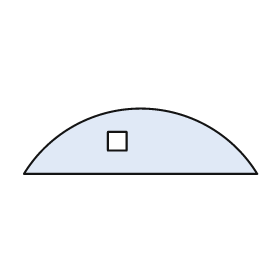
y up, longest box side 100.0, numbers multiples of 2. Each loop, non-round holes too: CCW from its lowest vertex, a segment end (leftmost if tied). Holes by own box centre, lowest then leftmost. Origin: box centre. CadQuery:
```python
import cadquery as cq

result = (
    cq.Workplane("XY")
    .moveTo(-50.0, -14.0)
    .lineTo(50.0, -14.0)
    .threePointArc((0.0, 14.0), (-50.0, -14.0))
    .close()
    .moveTo(-14.0, -4.0)
    .lineTo(-6.0, -4.0)
    .lineTo(-6.0, 4.0)
    .lineTo(-14.0, 4.0)
    .close()
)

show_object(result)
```